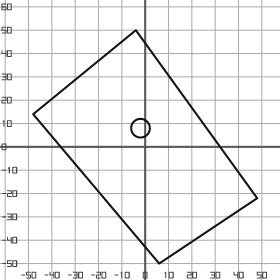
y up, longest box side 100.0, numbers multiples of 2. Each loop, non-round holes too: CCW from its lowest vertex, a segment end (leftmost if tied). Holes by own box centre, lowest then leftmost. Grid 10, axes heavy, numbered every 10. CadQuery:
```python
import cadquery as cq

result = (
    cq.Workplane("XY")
    .moveTo(6.0, -50.0)
    .lineTo(48.0, -22.0)
    .lineTo(-4.0, 50.0)
    .lineTo(-48.0, 14.0)
    .close()
    .moveTo(-2.0, 8.0)
    .circle(4.0)
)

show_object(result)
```